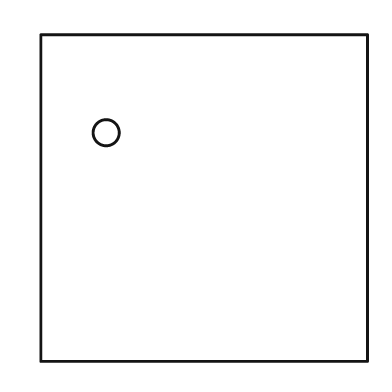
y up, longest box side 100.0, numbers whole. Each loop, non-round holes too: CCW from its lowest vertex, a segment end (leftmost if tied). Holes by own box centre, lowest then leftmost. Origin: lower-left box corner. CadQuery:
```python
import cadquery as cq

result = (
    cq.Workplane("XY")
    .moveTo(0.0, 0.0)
    .lineTo(100.0, 0.0)
    .lineTo(100.0, 100.0)
    .lineTo(0.0, 100.0)
    .close()
    .moveTo(20.0, 70.0)
    .circle(4.0)
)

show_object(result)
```